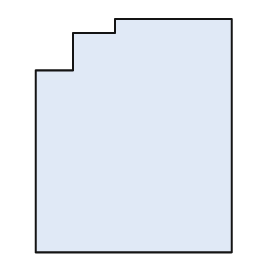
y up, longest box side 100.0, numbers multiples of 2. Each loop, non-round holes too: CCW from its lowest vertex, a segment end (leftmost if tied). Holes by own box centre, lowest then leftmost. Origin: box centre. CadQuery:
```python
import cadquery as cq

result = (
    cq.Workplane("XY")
    .moveTo(-42.0, -50.0)
    .lineTo(42.0, -50.0)
    .lineTo(42.0, 50.0)
    .lineTo(-8.0, 50.0)
    .lineTo(-8.0, 44.0)
    .lineTo(-26.0, 44.0)
    .lineTo(-26.0, 28.0)
    .lineTo(-42.0, 28.0)
    .close()
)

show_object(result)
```